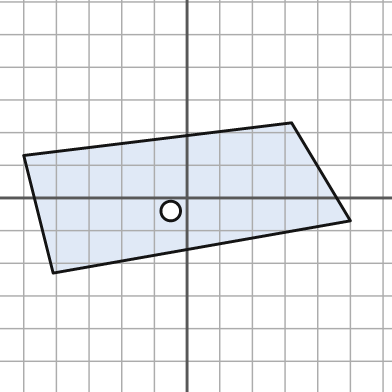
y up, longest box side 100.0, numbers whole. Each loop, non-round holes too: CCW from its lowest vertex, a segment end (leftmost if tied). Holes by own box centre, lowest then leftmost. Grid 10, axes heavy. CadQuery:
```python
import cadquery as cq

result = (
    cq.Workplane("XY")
    .moveTo(-41.0, -23.0)
    .lineTo(50.0, -7.0)
    .lineTo(32.0, 23.0)
    .lineTo(-50.0, 13.0)
    .close()
    .moveTo(-5.0, -4.0)
    .circle(3.0)
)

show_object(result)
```